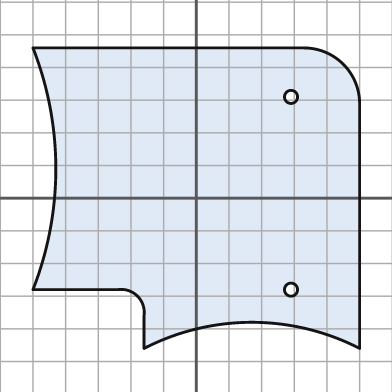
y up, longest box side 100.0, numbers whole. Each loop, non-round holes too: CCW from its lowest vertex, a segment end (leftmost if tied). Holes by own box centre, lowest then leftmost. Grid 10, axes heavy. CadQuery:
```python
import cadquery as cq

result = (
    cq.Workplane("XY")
    .moveTo(-16.0, -46.0)
    .threePointArc((17.0, -38.0), (50.0, -46.0))
    .lineTo(50.0, 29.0)
    .threePointArc((45.0, 41.0), (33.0, 46.0))
    .lineTo(-50.0, 46.0)
    .threePointArc((-43.0, 9.0), (-50.0, -28.0))
    .lineTo(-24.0, -28.0)
    .threePointArc((-18.0, -30.0), (-16.0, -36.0))
    .close()
    .moveTo(29.0, -28.0)
    .circle(2.0)
    .moveTo(29.0, 31.0)
    .circle(2.0)
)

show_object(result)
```